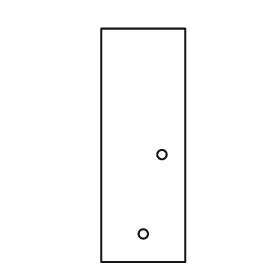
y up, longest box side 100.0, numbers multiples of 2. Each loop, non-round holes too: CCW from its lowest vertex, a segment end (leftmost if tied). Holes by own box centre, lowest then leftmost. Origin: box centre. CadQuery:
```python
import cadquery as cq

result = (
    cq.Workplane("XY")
    .moveTo(-18.0, -50.0)
    .lineTo(18.0, -50.0)
    .lineTo(18.0, 50.0)
    .lineTo(-18.0, 50.0)
    .close()
    .moveTo(0.0, -38.0)
    .circle(2.0)
    .moveTo(8.0, -4.0)
    .circle(2.0)
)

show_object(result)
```